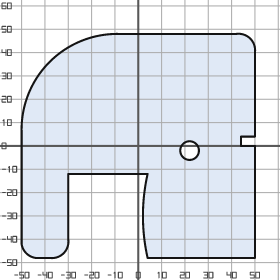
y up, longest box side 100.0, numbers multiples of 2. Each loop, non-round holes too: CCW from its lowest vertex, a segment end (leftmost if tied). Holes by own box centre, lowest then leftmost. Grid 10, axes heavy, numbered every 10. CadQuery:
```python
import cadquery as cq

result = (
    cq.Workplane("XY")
    .moveTo(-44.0, -48.0)
    .lineTo(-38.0, -48.0)
    .threePointArc((-32.0, -46.0), (-30.0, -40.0))
    .lineTo(-30.0, -12.0)
    .lineTo(4.0, -12.0)
    .threePointArc((2.0, -30.0), (4.0, -48.0))
    .lineTo(50.0, -48.0)
    .lineTo(50.0, 0.0)
    .lineTo(44.0, 0.0)
    .lineTo(44.0, 4.0)
    .lineTo(50.0, 4.0)
    .lineTo(50.0, 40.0)
    .threePointArc((48.0, 46.0), (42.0, 48.0))
    .lineTo(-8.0, 48.0)
    .threePointArc((-38.0, 36.0), (-50.0, 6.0))
    .lineTo(-50.0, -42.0)
    .threePointArc((-48.0, -46.0), (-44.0, -48.0))
    .close()
    .moveTo(22.0, -2.0)
    .circle(4.0)
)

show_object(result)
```